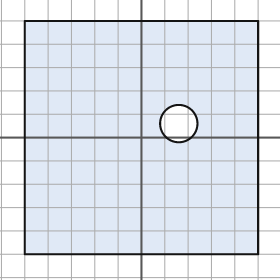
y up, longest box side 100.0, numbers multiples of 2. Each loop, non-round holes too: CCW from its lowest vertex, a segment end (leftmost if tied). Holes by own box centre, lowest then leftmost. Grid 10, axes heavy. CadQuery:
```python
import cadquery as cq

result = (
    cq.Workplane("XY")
    .moveTo(-50.0, -50.0)
    .lineTo(50.0, -50.0)
    .lineTo(50.0, 50.0)
    .lineTo(-50.0, 50.0)
    .close()
    .moveTo(16.0, 6.0)
    .circle(8.0)
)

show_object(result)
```